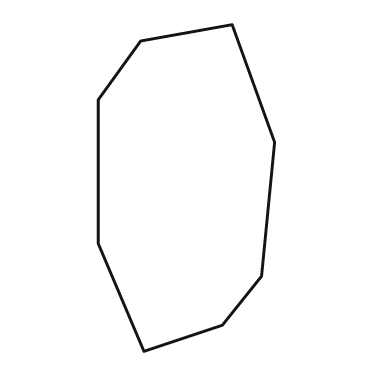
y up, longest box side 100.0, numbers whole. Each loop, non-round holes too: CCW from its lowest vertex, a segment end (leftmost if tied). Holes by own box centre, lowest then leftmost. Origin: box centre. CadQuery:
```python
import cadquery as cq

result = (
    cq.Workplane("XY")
    .moveTo(-13.0, -50.0)
    .lineTo(11.0, -42.0)
    .lineTo(23.0, -27.0)
    .lineTo(27.0, 14.0)
    .lineTo(14.0, 50.0)
    .lineTo(-14.0, 45.0)
    .lineTo(-27.0, 27.0)
    .lineTo(-27.0, -17.0)
    .close()
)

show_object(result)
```